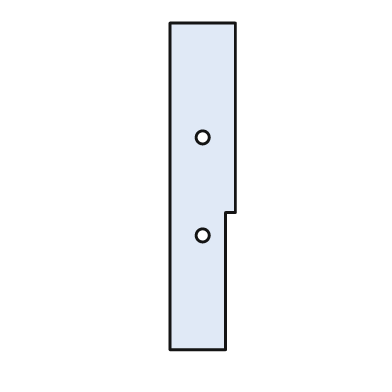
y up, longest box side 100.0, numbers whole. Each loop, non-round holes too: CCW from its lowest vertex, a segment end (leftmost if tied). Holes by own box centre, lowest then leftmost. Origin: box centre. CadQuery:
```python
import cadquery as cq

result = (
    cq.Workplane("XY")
    .moveTo(-10.0, -50.0)
    .lineTo(7.0, -50.0)
    .lineTo(7.0, -8.0)
    .lineTo(10.0, -8.0)
    .lineTo(10.0, 50.0)
    .lineTo(-10.0, 50.0)
    .close()
    .moveTo(0.0, -15.0)
    .circle(2.0)
    .moveTo(0.0, 15.0)
    .circle(2.0)
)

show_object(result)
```